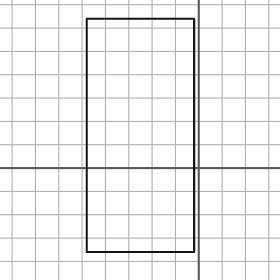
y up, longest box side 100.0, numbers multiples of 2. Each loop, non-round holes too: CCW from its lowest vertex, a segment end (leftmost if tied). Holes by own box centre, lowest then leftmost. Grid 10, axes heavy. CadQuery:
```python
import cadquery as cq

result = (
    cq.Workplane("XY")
    .moveTo(-48.0, -36.0)
    .lineTo(-2.0, -36.0)
    .lineTo(-2.0, 64.0)
    .lineTo(-48.0, 64.0)
    .close()
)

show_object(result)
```